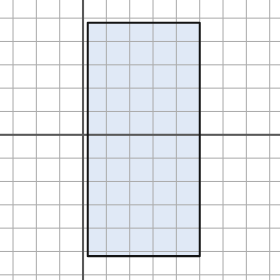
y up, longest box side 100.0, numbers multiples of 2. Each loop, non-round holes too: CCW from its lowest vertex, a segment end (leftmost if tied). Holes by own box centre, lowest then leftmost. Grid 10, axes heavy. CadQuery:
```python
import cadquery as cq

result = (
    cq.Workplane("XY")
    .moveTo(2.0, -52.0)
    .lineTo(50.0, -52.0)
    .lineTo(50.0, 48.0)
    .lineTo(2.0, 48.0)
    .close()
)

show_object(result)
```